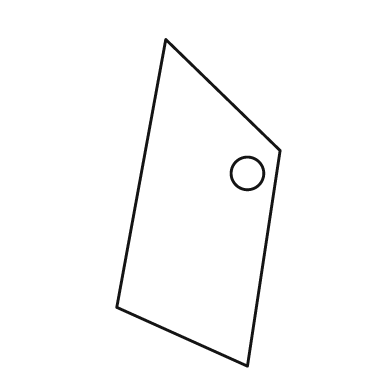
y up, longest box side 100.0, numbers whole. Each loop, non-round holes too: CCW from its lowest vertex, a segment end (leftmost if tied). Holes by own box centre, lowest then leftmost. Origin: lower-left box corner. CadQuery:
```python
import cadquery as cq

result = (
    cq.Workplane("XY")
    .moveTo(40.0, 0.0)
    .lineTo(50.0, 66.0)
    .lineTo(15.0, 100.0)
    .lineTo(0.0, 18.0)
    .close()
    .moveTo(40.0, 59.0)
    .circle(5.0)
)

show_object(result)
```